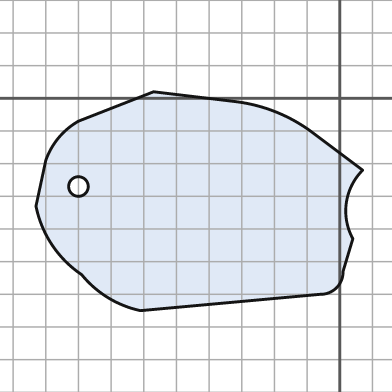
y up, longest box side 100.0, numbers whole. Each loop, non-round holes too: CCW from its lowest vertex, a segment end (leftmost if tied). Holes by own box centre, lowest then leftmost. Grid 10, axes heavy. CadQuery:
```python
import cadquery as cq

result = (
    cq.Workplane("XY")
    .moveTo(-61.0, -65.0)
    .lineTo(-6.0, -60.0)
    .threePointArc((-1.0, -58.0), (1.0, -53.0))
    .lineTo(4.0, -43.0)
    .threePointArc((2.0, -32.0), (7.0, -22.0))
    .lineTo(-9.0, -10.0)
    .threePointArc((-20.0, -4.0), (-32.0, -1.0))
    .lineTo(-57.0, 2.0)
    .lineTo(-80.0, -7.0)
    .threePointArc((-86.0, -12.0), (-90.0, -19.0))
    .lineTo(-93.0, -33.0)
    .threePointArc((-88.0, -45.0), (-79.0, -54.0))
    .threePointArc((-71.0, -61.0), (-61.0, -65.0))
    .close()
    .moveTo(-80.0, -27.0)
    .circle(3.0)
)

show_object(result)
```